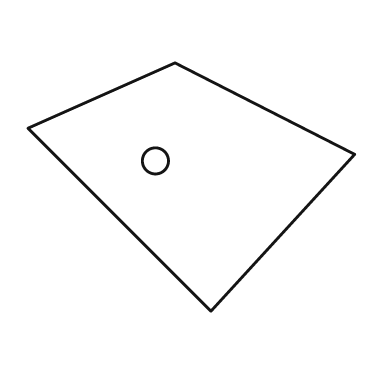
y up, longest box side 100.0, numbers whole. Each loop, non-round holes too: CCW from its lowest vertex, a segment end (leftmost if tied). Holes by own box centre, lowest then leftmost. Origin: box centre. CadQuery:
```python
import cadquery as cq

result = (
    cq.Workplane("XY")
    .moveTo(6.0, -38.0)
    .lineTo(50.0, 10.0)
    .lineTo(-5.0, 38.0)
    .lineTo(-50.0, 18.0)
    .close()
    .moveTo(-11.0, 8.0)
    .circle(4.0)
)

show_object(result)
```